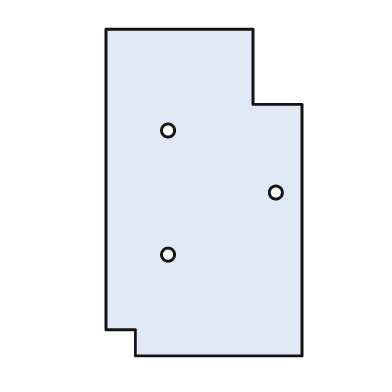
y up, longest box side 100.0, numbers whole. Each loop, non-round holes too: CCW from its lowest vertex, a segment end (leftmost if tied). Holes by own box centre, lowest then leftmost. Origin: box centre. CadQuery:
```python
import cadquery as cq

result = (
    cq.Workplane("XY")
    .moveTo(-21.0, -50.0)
    .lineTo(30.0, -50.0)
    .lineTo(30.0, 27.0)
    .lineTo(15.0, 27.0)
    .lineTo(15.0, 50.0)
    .lineTo(-30.0, 50.0)
    .lineTo(-30.0, -42.0)
    .lineTo(-21.0, -42.0)
    .close()
    .moveTo(-11.0, -19.0)
    .circle(2.0)
    .moveTo(22.0, 0.0)
    .circle(2.0)
    .moveTo(-11.0, 19.0)
    .circle(2.0)
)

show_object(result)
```